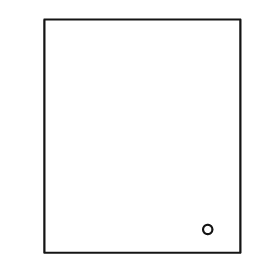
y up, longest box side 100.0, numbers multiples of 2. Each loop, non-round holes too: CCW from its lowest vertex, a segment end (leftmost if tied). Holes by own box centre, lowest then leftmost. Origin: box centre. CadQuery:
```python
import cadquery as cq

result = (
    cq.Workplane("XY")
    .moveTo(-42.0, -50.0)
    .lineTo(42.0, -50.0)
    .lineTo(42.0, 50.0)
    .lineTo(-42.0, 50.0)
    .close()
    .moveTo(28.0, -40.0)
    .circle(2.0)
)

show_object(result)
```